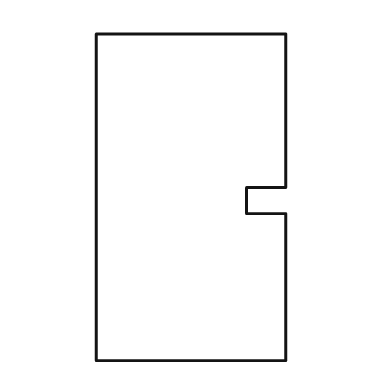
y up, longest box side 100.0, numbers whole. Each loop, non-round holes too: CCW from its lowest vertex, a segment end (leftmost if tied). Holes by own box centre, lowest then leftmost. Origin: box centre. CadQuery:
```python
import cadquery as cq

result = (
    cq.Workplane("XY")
    .moveTo(-29.0, -50.0)
    .lineTo(29.0, -50.0)
    .lineTo(29.0, -5.0)
    .lineTo(17.0, -5.0)
    .lineTo(17.0, 3.0)
    .lineTo(29.0, 3.0)
    .lineTo(29.0, 50.0)
    .lineTo(-29.0, 50.0)
    .close()
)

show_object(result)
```